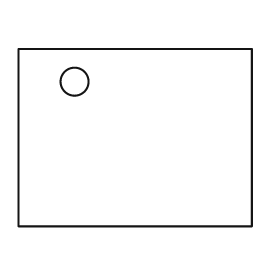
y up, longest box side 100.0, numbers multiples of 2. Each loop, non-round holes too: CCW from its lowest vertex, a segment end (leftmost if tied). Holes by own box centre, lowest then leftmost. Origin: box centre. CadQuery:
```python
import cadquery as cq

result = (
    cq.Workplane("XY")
    .moveTo(-50.0, -38.0)
    .lineTo(50.0, -38.0)
    .lineTo(50.0, 38.0)
    .lineTo(-50.0, 38.0)
    .close()
    .moveTo(-26.0, 24.0)
    .circle(6.0)
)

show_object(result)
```